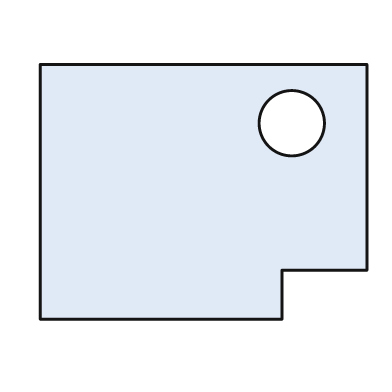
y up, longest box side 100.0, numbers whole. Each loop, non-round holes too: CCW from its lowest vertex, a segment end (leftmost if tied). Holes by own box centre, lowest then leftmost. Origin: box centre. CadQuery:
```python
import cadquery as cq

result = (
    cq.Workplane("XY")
    .moveTo(-50.0, -39.0)
    .lineTo(24.0, -39.0)
    .lineTo(24.0, -24.0)
    .lineTo(50.0, -24.0)
    .lineTo(50.0, 39.0)
    .lineTo(-50.0, 39.0)
    .close()
    .moveTo(27.0, 21.0)
    .circle(10.0)
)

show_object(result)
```